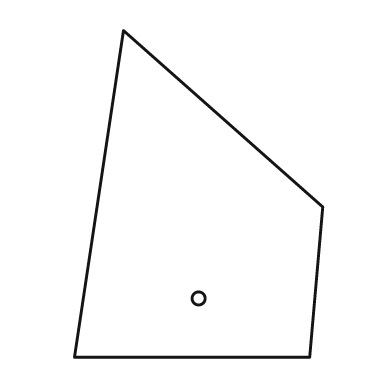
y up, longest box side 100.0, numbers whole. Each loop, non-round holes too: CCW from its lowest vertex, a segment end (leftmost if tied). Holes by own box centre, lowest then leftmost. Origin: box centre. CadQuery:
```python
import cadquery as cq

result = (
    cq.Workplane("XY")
    .moveTo(-38.0, -50.0)
    .lineTo(34.0, -50.0)
    .lineTo(38.0, -4.0)
    .lineTo(-23.0, 50.0)
    .close()
    .moveTo(0.0, -32.0)
    .circle(2.0)
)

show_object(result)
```